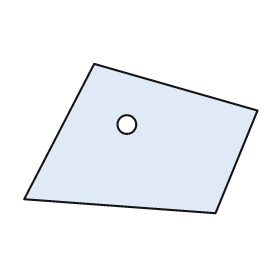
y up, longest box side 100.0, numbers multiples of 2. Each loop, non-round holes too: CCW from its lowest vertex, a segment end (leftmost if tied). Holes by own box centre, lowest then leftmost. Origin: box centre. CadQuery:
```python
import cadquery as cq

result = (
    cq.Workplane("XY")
    .moveTo(32.0, -32.0)
    .lineTo(50.0, 12.0)
    .lineTo(-20.0, 32.0)
    .lineTo(-50.0, -26.0)
    .close()
    .moveTo(-6.0, 6.0)
    .circle(4.0)
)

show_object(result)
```